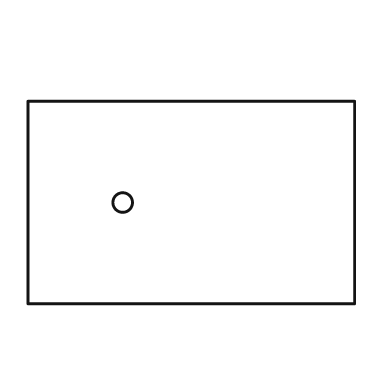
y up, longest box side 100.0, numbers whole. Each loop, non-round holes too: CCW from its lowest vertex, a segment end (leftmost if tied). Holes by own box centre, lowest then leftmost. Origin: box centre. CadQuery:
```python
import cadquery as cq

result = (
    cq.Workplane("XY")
    .moveTo(-50.0, -31.0)
    .lineTo(50.0, -31.0)
    .lineTo(50.0, 31.0)
    .lineTo(-50.0, 31.0)
    .close()
    .moveTo(-21.0, 0.0)
    .circle(3.0)
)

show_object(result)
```